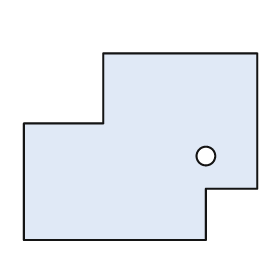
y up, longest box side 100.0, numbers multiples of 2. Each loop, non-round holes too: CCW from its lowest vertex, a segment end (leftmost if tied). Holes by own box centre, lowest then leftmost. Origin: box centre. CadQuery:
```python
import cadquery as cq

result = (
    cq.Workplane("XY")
    .moveTo(-50.0, -40.0)
    .lineTo(28.0, -40.0)
    .lineTo(28.0, -18.0)
    .lineTo(50.0, -18.0)
    .lineTo(50.0, 40.0)
    .lineTo(-16.0, 40.0)
    .lineTo(-16.0, 10.0)
    .lineTo(-50.0, 10.0)
    .close()
    .moveTo(28.0, -4.0)
    .circle(4.0)
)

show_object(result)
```